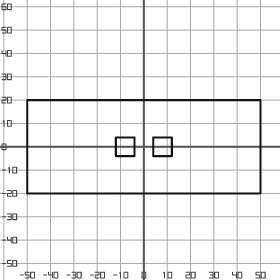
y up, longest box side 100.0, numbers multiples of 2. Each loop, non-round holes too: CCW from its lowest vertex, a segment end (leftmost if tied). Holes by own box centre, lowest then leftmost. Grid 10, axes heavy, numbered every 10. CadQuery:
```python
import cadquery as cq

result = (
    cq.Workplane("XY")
    .moveTo(-50.0, -20.0)
    .lineTo(50.0, -20.0)
    .lineTo(50.0, 20.0)
    .lineTo(-50.0, 20.0)
    .close()
    .moveTo(-12.0, -4.0)
    .lineTo(-4.0, -4.0)
    .lineTo(-4.0, 4.0)
    .lineTo(-12.0, 4.0)
    .close()
    .moveTo(4.0, -4.0)
    .lineTo(12.0, -4.0)
    .lineTo(12.0, 4.0)
    .lineTo(4.0, 4.0)
    .close()
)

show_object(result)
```